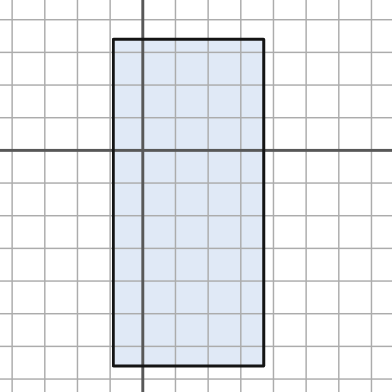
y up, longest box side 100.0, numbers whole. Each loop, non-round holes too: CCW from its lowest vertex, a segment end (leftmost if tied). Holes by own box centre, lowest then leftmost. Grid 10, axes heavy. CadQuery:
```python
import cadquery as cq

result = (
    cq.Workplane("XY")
    .moveTo(-9.0, -66.0)
    .lineTo(37.0, -66.0)
    .lineTo(37.0, 34.0)
    .lineTo(-9.0, 34.0)
    .close()
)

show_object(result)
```